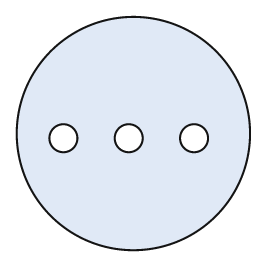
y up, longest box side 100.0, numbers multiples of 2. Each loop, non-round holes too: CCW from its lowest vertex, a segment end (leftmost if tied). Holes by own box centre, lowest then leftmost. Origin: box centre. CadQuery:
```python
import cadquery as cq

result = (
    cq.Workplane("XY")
    .moveTo(0.0, 0.0)
    .circle(50.0)
    .moveTo(-30.0, -2.0)
    .circle(6.0)
    .moveTo(-2.0, -2.0)
    .circle(6.0)
    .moveTo(26.0, -2.0)
    .circle(6.0)
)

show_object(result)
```